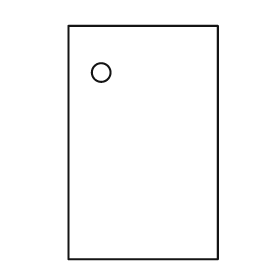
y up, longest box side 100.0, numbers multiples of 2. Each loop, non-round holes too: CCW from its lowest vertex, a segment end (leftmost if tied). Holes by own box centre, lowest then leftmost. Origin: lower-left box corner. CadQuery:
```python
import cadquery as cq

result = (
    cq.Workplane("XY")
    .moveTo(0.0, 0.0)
    .lineTo(64.0, 0.0)
    .lineTo(64.0, 100.0)
    .lineTo(0.0, 100.0)
    .close()
    .moveTo(14.0, 80.0)
    .circle(4.0)
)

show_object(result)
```